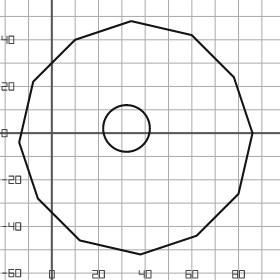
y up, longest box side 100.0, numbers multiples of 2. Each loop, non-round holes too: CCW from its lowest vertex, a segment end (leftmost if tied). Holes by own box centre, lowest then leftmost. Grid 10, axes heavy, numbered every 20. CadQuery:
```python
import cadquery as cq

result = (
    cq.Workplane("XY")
    .moveTo(38.0, -52.0)
    .lineTo(62.0, -44.0)
    .lineTo(80.0, -26.0)
    .lineTo(86.0, 0.0)
    .lineTo(78.0, 24.0)
    .lineTo(60.0, 42.0)
    .lineTo(34.0, 48.0)
    .lineTo(10.0, 40.0)
    .lineTo(-8.0, 22.0)
    .lineTo(-14.0, -4.0)
    .lineTo(-6.0, -28.0)
    .lineTo(12.0, -46.0)
    .close()
    .moveTo(32.0, 2.0)
    .circle(10.0)
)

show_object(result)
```